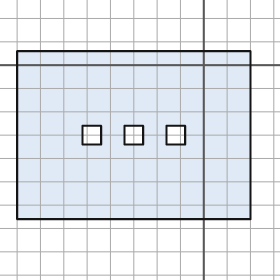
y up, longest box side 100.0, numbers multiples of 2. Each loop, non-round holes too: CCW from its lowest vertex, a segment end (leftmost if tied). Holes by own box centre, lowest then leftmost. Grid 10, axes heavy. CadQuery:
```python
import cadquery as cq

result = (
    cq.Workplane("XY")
    .moveTo(-80.0, -66.0)
    .lineTo(20.0, -66.0)
    .lineTo(20.0, 6.0)
    .lineTo(-80.0, 6.0)
    .close()
    .moveTo(-52.0, -34.0)
    .lineTo(-44.0, -34.0)
    .lineTo(-44.0, -26.0)
    .lineTo(-52.0, -26.0)
    .close()
    .moveTo(-34.0, -34.0)
    .lineTo(-26.0, -34.0)
    .lineTo(-26.0, -26.0)
    .lineTo(-34.0, -26.0)
    .close()
    .moveTo(-16.0, -34.0)
    .lineTo(-8.0, -34.0)
    .lineTo(-8.0, -26.0)
    .lineTo(-16.0, -26.0)
    .close()
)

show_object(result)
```